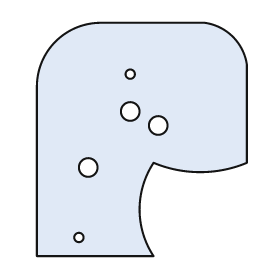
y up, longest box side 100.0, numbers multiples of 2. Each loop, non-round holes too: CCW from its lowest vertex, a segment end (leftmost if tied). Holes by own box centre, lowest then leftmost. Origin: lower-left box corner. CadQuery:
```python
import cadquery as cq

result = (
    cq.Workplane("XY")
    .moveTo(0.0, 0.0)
    .lineTo(50.0, 0.0)
    .threePointArc((44.0, 20.0), (50.0, 40.0))
    .threePointArc((70.0, 36.0), (90.0, 40.0))
    .lineTo(90.0, 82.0)
    .threePointArc((84.0, 94.0), (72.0, 100.0))
    .lineTo(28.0, 100.0)
    .threePointArc((8.0, 92.0), (0.0, 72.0))
    .close()
    .moveTo(18.0, 8.0)
    .circle(2.0)
    .moveTo(22.0, 38.0)
    .circle(4.0)
    .moveTo(52.0, 56.0)
    .circle(4.0)
    .moveTo(40.0, 62.0)
    .circle(4.0)
    .moveTo(40.0, 78.0)
    .circle(2.0)
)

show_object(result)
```